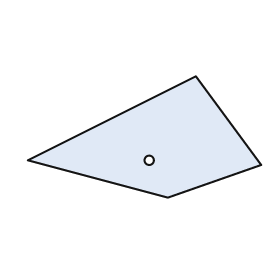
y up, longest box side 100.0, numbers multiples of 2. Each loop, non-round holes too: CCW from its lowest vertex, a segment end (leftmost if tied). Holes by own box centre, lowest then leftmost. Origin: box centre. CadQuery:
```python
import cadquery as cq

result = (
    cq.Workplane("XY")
    .moveTo(10.0, -26.0)
    .lineTo(50.0, -12.0)
    .lineTo(22.0, 26.0)
    .lineTo(-50.0, -10.0)
    .close()
    .moveTo(2.0, -10.0)
    .circle(2.0)
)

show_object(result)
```